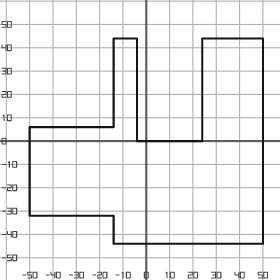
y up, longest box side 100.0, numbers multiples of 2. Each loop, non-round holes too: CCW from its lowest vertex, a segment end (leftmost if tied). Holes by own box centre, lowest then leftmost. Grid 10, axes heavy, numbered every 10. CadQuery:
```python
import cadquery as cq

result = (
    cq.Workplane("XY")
    .moveTo(-14.0, -44.0)
    .lineTo(50.0, -44.0)
    .lineTo(50.0, 44.0)
    .lineTo(24.0, 44.0)
    .lineTo(24.0, 0.0)
    .lineTo(-4.0, 0.0)
    .lineTo(-4.0, 44.0)
    .lineTo(-14.0, 44.0)
    .lineTo(-14.0, 6.0)
    .lineTo(-50.0, 6.0)
    .lineTo(-50.0, -32.0)
    .lineTo(-14.0, -32.0)
    .close()
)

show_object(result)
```